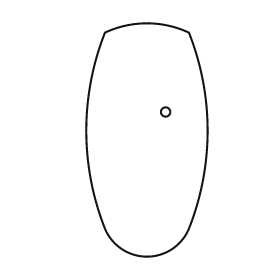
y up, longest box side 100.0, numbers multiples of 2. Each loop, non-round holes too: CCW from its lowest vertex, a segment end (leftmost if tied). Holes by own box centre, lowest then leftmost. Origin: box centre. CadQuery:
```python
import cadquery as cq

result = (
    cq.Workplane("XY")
    .moveTo(-18.0, -38.0)
    .threePointArc((0.0, -50.0), (18.0, -38.0))
    .threePointArc((26.0, 4.0), (18.0, 46.0))
    .threePointArc((0.0, 50.0), (-18.0, 46.0))
    .threePointArc((-26.0, 4.0), (-18.0, -38.0))
    .close()
    .moveTo(8.0, 12.0)
    .circle(2.0)
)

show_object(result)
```